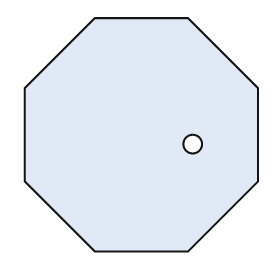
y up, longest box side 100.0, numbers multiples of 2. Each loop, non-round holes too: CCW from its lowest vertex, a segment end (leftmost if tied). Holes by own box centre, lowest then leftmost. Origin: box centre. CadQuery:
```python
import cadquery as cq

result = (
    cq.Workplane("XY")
    .moveTo(-20.0, -50.0)
    .lineTo(20.0, -50.0)
    .lineTo(50.0, -20.0)
    .lineTo(50.0, 20.0)
    .lineTo(20.0, 50.0)
    .lineTo(-20.0, 50.0)
    .lineTo(-50.0, 20.0)
    .lineTo(-50.0, -20.0)
    .close()
    .moveTo(22.0, -4.0)
    .circle(4.0)
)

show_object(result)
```